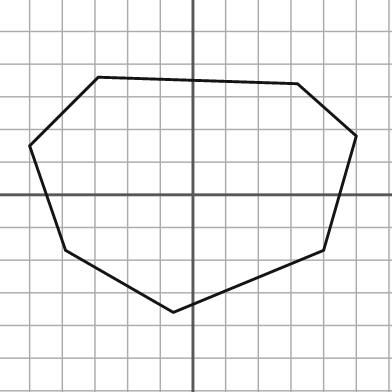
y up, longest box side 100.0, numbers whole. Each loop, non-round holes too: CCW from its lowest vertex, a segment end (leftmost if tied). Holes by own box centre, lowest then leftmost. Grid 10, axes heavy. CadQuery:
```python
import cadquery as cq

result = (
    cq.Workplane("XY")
    .moveTo(-6.0, -36.0)
    .lineTo(40.0, -17.0)
    .lineTo(50.0, 18.0)
    .lineTo(32.0, 34.0)
    .lineTo(-29.0, 36.0)
    .lineTo(-50.0, 15.0)
    .lineTo(-39.0, -17.0)
    .close()
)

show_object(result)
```